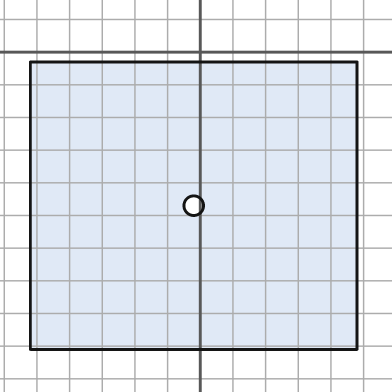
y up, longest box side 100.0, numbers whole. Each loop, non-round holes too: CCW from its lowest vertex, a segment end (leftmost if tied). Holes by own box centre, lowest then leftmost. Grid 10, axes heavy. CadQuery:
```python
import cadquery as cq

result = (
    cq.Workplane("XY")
    .moveTo(-52.0, -91.0)
    .lineTo(48.0, -91.0)
    .lineTo(48.0, -3.0)
    .lineTo(-52.0, -3.0)
    .close()
    .moveTo(-2.0, -47.0)
    .circle(3.0)
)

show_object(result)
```